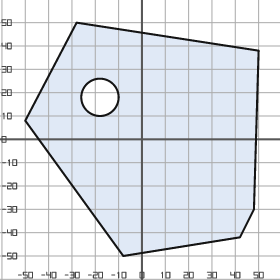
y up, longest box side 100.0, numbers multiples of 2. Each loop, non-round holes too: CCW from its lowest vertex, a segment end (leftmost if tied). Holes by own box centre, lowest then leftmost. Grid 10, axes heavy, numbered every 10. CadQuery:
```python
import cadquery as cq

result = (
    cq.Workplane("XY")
    .moveTo(-8.0, -50.0)
    .lineTo(42.0, -42.0)
    .lineTo(48.0, -30.0)
    .lineTo(50.0, 38.0)
    .lineTo(-28.0, 50.0)
    .lineTo(-50.0, 8.0)
    .close()
    .moveTo(-18.0, 18.0)
    .circle(8.0)
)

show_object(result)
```